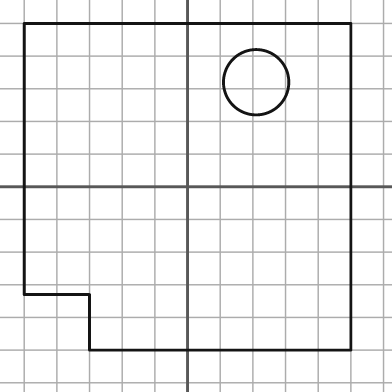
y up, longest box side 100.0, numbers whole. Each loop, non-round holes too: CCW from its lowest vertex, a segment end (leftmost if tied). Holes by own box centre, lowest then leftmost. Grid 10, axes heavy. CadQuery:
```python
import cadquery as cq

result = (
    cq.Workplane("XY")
    .moveTo(-30.0, -50.0)
    .lineTo(50.0, -50.0)
    .lineTo(50.0, 50.0)
    .lineTo(-50.0, 50.0)
    .lineTo(-50.0, -33.0)
    .lineTo(-30.0, -33.0)
    .close()
    .moveTo(21.0, 32.0)
    .circle(10.0)
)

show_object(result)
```